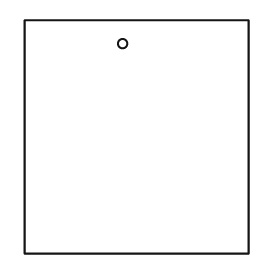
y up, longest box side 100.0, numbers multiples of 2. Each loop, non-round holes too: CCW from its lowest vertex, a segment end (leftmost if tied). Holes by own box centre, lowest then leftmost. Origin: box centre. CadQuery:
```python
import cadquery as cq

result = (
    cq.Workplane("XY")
    .moveTo(-48.0, -50.0)
    .lineTo(48.0, -50.0)
    .lineTo(48.0, 50.0)
    .lineTo(-48.0, 50.0)
    .close()
    .moveTo(-6.0, 40.0)
    .circle(2.0)
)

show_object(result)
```